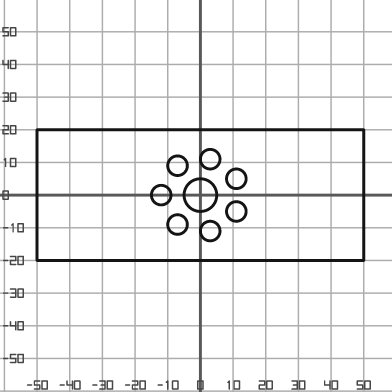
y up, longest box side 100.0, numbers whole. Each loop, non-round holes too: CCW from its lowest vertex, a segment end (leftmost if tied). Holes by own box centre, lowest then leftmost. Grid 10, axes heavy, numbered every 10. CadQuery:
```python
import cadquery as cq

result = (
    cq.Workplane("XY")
    .moveTo(-50.0, -20.0)
    .lineTo(50.0, -20.0)
    .lineTo(50.0, 20.0)
    .lineTo(-50.0, 20.0)
    .close()
    .moveTo(3.0, -11.0)
    .circle(3.0)
    .moveTo(-7.0, -9.0)
    .circle(3.0)
    .moveTo(11.0, -5.0)
    .circle(3.0)
    .moveTo(-12.0, 0.0)
    .circle(3.0)
    .moveTo(0.0, 0.0)
    .circle(5.0)
    .moveTo(11.0, 5.0)
    .circle(3.0)
    .moveTo(-7.0, 9.0)
    .circle(3.0)
    .moveTo(3.0, 11.0)
    .circle(3.0)
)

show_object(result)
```